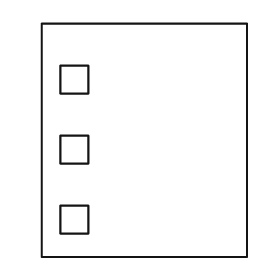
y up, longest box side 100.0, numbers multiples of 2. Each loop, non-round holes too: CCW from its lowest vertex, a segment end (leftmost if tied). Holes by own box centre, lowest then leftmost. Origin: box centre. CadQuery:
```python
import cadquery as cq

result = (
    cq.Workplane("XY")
    .moveTo(-44.0, -50.0)
    .lineTo(44.0, -50.0)
    .lineTo(44.0, 50.0)
    .lineTo(-44.0, 50.0)
    .close()
    .moveTo(-36.0, -40.0)
    .lineTo(-24.0, -40.0)
    .lineTo(-24.0, -28.0)
    .lineTo(-36.0, -28.0)
    .close()
    .moveTo(-36.0, -10.0)
    .lineTo(-24.0, -10.0)
    .lineTo(-24.0, 2.0)
    .lineTo(-36.0, 2.0)
    .close()
    .moveTo(-36.0, 20.0)
    .lineTo(-24.0, 20.0)
    .lineTo(-24.0, 32.0)
    .lineTo(-36.0, 32.0)
    .close()
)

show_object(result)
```